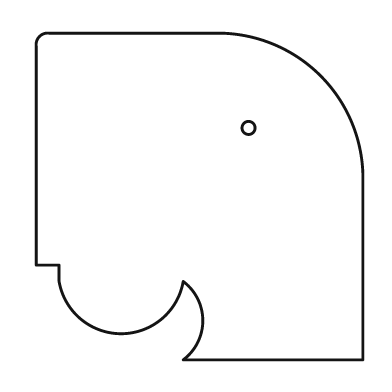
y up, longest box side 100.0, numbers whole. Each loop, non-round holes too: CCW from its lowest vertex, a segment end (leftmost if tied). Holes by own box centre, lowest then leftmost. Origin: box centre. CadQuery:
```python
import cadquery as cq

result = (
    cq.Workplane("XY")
    .moveTo(-5.0, -50.0)
    .lineTo(50.0, -50.0)
    .lineTo(50.0, 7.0)
    .threePointArc((37.0, 37.0), (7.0, 50.0))
    .lineTo(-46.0, 50.0)
    .threePointArc((-49.0, 49.0), (-50.0, 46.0))
    .lineTo(-50.0, -21.0)
    .lineTo(-43.0, -21.0)
    .lineTo(-43.0, -26.0)
    .threePointArc((-24.0, -42.0), (-5.0, -26.0))
    .threePointArc((1.0, -38.0), (-5.0, -50.0))
    .close()
    .moveTo(15.0, 21.0)
    .circle(2.0)
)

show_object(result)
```